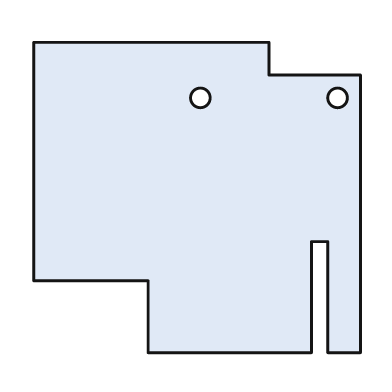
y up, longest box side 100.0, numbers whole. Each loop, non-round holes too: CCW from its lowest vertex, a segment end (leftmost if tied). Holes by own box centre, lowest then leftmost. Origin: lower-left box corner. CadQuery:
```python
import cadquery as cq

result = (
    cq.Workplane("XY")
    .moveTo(35.0, 0.0)
    .lineTo(85.0, 0.0)
    .lineTo(85.0, 34.0)
    .lineTo(90.0, 34.0)
    .lineTo(90.0, 0.0)
    .lineTo(100.0, 0.0)
    .lineTo(100.0, 85.0)
    .lineTo(72.0, 85.0)
    .lineTo(72.0, 95.0)
    .lineTo(0.0, 95.0)
    .lineTo(0.0, 22.0)
    .lineTo(35.0, 22.0)
    .close()
    .moveTo(51.0, 78.0)
    .circle(3.0)
    .moveTo(93.0, 78.0)
    .circle(3.0)
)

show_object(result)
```